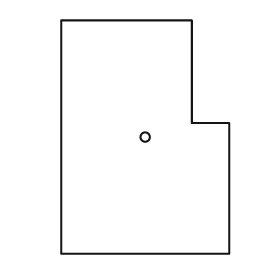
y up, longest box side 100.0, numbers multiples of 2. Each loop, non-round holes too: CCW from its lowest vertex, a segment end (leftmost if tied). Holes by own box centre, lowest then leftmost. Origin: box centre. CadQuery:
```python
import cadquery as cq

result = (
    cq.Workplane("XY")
    .moveTo(-36.0, -50.0)
    .lineTo(36.0, -50.0)
    .lineTo(36.0, 6.0)
    .lineTo(20.0, 6.0)
    .lineTo(20.0, 50.0)
    .lineTo(-36.0, 50.0)
    .close()
    .moveTo(0.0, 0.0)
    .circle(2.0)
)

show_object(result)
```